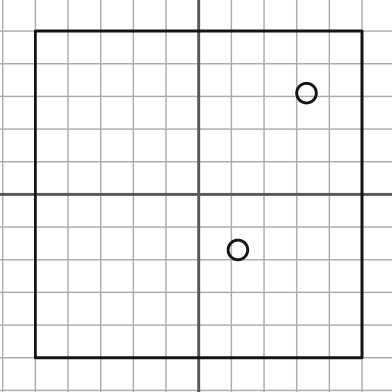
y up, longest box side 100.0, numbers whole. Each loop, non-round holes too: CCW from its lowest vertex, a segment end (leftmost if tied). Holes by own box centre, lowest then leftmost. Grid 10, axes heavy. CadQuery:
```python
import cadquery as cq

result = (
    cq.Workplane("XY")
    .moveTo(-50.0, -50.0)
    .lineTo(50.0, -50.0)
    .lineTo(50.0, 50.0)
    .lineTo(-50.0, 50.0)
    .close()
    .moveTo(12.0, -17.0)
    .circle(3.0)
    .moveTo(33.0, 31.0)
    .circle(3.0)
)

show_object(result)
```